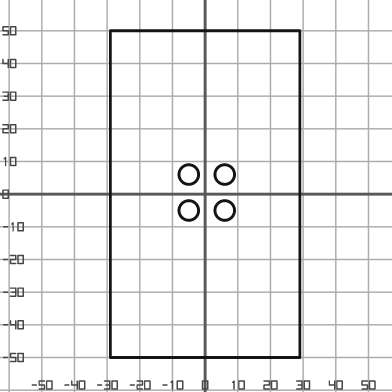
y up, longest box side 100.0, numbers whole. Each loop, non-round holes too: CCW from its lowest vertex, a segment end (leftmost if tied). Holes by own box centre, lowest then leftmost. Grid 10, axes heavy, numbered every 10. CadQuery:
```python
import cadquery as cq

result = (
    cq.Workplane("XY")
    .moveTo(-29.0, -50.0)
    .lineTo(29.0, -50.0)
    .lineTo(29.0, 50.0)
    .lineTo(-29.0, 50.0)
    .close()
    .moveTo(-5.0, -5.0)
    .circle(3.0)
    .moveTo(6.0, -5.0)
    .circle(3.0)
    .moveTo(-5.0, 6.0)
    .circle(3.0)
    .moveTo(6.0, 6.0)
    .circle(3.0)
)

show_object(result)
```